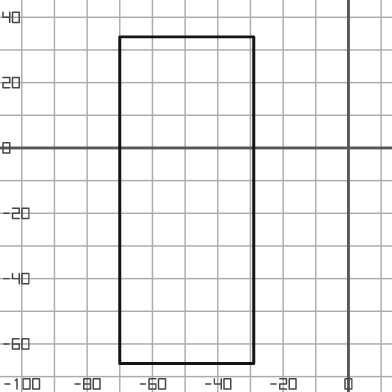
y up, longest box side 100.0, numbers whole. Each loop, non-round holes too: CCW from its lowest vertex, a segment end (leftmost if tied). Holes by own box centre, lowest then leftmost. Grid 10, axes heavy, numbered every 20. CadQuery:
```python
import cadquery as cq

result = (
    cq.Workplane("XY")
    .moveTo(-70.0, -66.0)
    .lineTo(-29.0, -66.0)
    .lineTo(-29.0, 34.0)
    .lineTo(-70.0, 34.0)
    .close()
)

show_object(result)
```